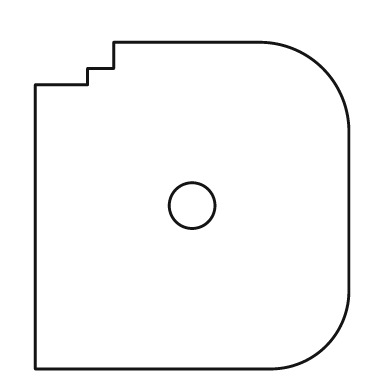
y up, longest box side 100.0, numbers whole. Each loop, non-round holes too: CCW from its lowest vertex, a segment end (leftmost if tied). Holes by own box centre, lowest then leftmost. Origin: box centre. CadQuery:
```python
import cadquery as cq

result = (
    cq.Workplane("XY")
    .moveTo(-48.0, -50.0)
    .lineTo(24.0, -50.0)
    .threePointArc((41.0, -43.0), (48.0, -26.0))
    .lineTo(48.0, 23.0)
    .threePointArc((40.0, 42.0), (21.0, 50.0))
    .lineTo(-24.0, 50.0)
    .lineTo(-24.0, 42.0)
    .lineTo(-32.0, 42.0)
    .lineTo(-32.0, 37.0)
    .lineTo(-48.0, 37.0)
    .close()
    .moveTo(0.0, 0.0)
    .circle(7.0)
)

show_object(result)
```